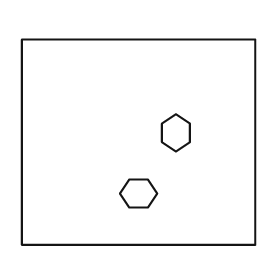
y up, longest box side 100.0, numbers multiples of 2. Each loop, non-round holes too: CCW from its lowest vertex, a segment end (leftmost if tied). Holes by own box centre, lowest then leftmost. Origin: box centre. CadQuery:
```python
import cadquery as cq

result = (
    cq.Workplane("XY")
    .moveTo(-50.0, -44.0)
    .lineTo(50.0, -44.0)
    .lineTo(50.0, 44.0)
    .lineTo(-50.0, 44.0)
    .close()
    .moveTo(-4.0, -28.0)
    .lineTo(4.0, -28.0)
    .lineTo(8.0, -22.0)
    .lineTo(4.0, -16.0)
    .lineTo(-4.0, -16.0)
    .lineTo(-8.0, -22.0)
    .close()
    .moveTo(16.0, -4.0)
    .lineTo(22.0, 0.0)
    .lineTo(22.0, 8.0)
    .lineTo(16.0, 12.0)
    .lineTo(10.0, 8.0)
    .lineTo(10.0, 0.0)
    .close()
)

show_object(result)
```